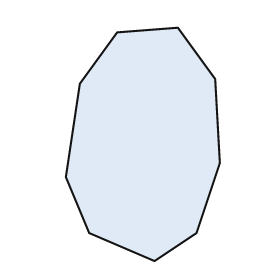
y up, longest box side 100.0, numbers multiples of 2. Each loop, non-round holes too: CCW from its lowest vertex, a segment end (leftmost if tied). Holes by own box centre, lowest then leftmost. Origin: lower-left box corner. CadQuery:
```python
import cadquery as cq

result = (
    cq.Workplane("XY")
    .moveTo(38.0, 0.0)
    .lineTo(56.0, 12.0)
    .lineTo(66.0, 42.0)
    .lineTo(64.0, 78.0)
    .lineTo(48.0, 100.0)
    .lineTo(22.0, 98.0)
    .lineTo(6.0, 76.0)
    .lineTo(0.0, 36.0)
    .lineTo(10.0, 12.0)
    .close()
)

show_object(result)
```